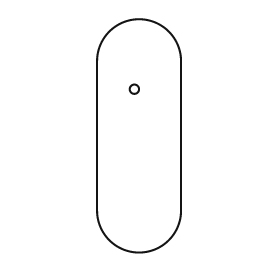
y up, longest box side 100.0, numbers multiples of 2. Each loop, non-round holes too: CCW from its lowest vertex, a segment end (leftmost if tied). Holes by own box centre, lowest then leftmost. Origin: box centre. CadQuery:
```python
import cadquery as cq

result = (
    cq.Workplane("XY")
    .moveTo(-18.0, -32.0)
    .threePointArc((0.0, -50.0), (18.0, -32.0))
    .lineTo(18.0, 32.0)
    .threePointArc((0.0, 50.0), (-18.0, 32.0))
    .close()
    .moveTo(-2.0, 20.0)
    .circle(2.0)
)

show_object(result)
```